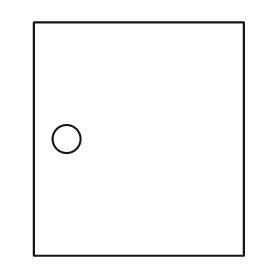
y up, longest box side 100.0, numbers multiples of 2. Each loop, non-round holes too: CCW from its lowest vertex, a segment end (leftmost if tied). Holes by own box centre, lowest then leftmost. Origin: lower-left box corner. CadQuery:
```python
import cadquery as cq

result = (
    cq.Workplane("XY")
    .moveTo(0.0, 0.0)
    .lineTo(90.0, 0.0)
    .lineTo(90.0, 100.0)
    .lineTo(0.0, 100.0)
    .close()
    .moveTo(14.0, 50.0)
    .circle(6.0)
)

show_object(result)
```